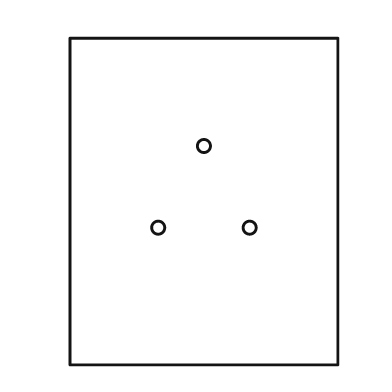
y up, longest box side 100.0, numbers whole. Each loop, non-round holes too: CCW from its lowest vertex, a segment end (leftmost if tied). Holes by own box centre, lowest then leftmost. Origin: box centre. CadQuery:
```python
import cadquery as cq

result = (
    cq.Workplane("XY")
    .moveTo(-41.0, -50.0)
    .lineTo(41.0, -50.0)
    .lineTo(41.0, 50.0)
    .lineTo(-41.0, 50.0)
    .close()
    .moveTo(-14.0, -8.0)
    .circle(2.0)
    .moveTo(14.0, -8.0)
    .circle(2.0)
    .moveTo(0.0, 17.0)
    .circle(2.0)
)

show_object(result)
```